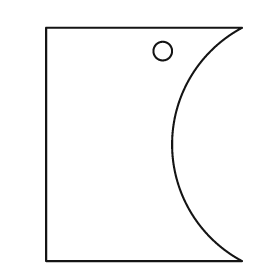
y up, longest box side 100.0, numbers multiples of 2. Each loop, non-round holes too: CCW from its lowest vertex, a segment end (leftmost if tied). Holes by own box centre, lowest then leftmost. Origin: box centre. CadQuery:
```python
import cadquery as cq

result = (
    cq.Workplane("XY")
    .moveTo(-42.0, -50.0)
    .lineTo(42.0, -50.0)
    .threePointArc((12.0, 0.0), (42.0, 50.0))
    .lineTo(-42.0, 50.0)
    .close()
    .moveTo(8.0, 40.0)
    .circle(4.0)
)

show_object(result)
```